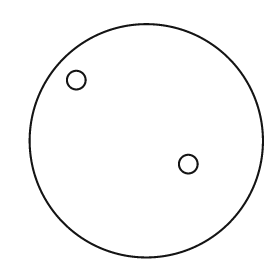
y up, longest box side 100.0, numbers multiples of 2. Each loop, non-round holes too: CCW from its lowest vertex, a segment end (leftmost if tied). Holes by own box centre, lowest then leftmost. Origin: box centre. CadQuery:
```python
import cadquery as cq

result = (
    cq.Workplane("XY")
    .moveTo(0.0, 0.0)
    .circle(50.0)
    .moveTo(18.0, -10.0)
    .circle(4.0)
    .moveTo(-30.0, 26.0)
    .circle(4.0)
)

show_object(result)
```